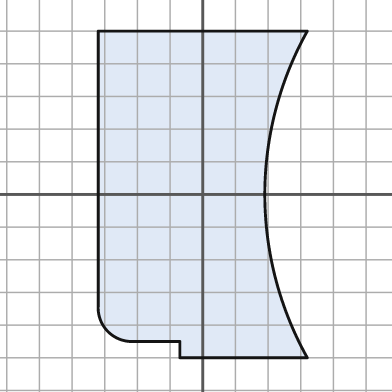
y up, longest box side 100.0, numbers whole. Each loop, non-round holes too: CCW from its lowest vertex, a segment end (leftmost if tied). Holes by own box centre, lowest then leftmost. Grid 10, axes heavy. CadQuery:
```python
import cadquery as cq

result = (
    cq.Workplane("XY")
    .moveTo(-7.0, -50.0)
    .lineTo(32.0, -50.0)
    .threePointArc((19.0, 0.0), (32.0, 50.0))
    .lineTo(-32.0, 50.0)
    .lineTo(-32.0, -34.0)
    .threePointArc((-29.0, -42.0), (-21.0, -45.0))
    .lineTo(-7.0, -45.0)
    .close()
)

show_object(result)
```